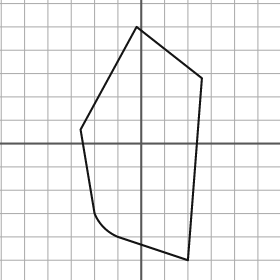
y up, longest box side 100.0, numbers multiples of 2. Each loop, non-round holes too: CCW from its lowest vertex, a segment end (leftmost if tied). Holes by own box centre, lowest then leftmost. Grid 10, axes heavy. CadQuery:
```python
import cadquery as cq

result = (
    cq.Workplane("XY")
    .moveTo(20.0, -50.0)
    .lineTo(26.0, 28.0)
    .lineTo(-2.0, 50.0)
    .lineTo(-26.0, 6.0)
    .lineTo(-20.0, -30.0)
    .threePointArc((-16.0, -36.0), (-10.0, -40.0))
    .close()
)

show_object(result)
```